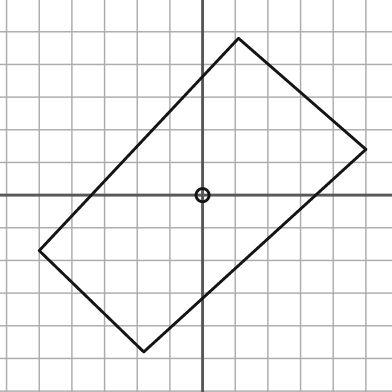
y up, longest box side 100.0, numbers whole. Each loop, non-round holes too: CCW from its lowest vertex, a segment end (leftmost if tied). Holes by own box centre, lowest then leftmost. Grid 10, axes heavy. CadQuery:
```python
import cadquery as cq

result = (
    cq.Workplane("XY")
    .moveTo(-18.0, -48.0)
    .lineTo(50.0, 14.0)
    .lineTo(11.0, 48.0)
    .lineTo(-50.0, -17.0)
    .close()
    .moveTo(0.0, 0.0)
    .circle(2.0)
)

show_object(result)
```